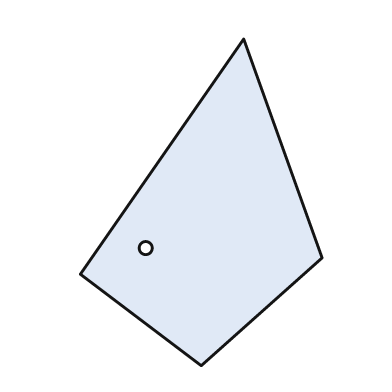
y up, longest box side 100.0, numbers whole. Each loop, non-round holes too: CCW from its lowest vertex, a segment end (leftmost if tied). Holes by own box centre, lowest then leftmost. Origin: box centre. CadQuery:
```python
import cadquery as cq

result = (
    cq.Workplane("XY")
    .moveTo(0.0, -50.0)
    .lineTo(37.0, -17.0)
    .lineTo(13.0, 50.0)
    .lineTo(-37.0, -22.0)
    .close()
    .moveTo(-17.0, -14.0)
    .circle(2.0)
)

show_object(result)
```